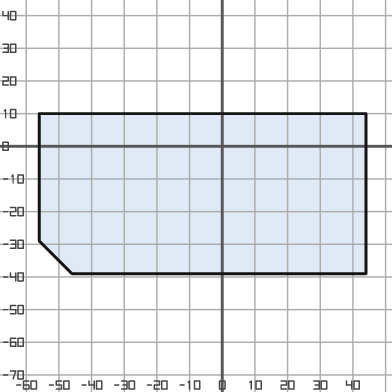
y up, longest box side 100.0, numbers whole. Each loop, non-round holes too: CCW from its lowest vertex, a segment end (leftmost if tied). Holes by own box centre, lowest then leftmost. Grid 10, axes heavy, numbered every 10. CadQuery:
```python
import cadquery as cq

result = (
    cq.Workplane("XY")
    .moveTo(-46.0, -39.0)
    .lineTo(44.0, -39.0)
    .lineTo(44.0, 10.0)
    .lineTo(-56.0, 10.0)
    .lineTo(-56.0, -29.0)
    .close()
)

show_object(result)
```